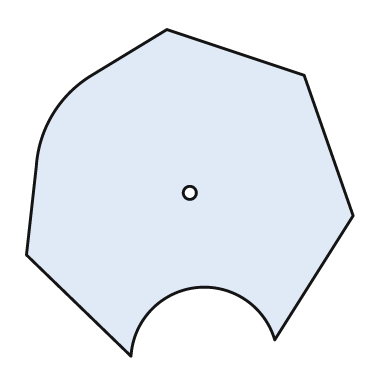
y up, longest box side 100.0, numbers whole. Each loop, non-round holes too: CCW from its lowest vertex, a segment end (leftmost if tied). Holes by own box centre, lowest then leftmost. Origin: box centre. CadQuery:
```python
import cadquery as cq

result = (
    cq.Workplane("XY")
    .moveTo(-18.0, -50.0)
    .threePointArc((2.0, -29.0), (26.0, -45.0))
    .lineTo(50.0, -7.0)
    .lineTo(35.0, 36.0)
    .lineTo(-7.0, 50.0)
    .lineTo(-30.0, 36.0)
    .threePointArc((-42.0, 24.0), (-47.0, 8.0))
    .lineTo(-50.0, -19.0)
    .close()
    .moveTo(0.0, 0.0)
    .circle(2.0)
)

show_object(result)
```